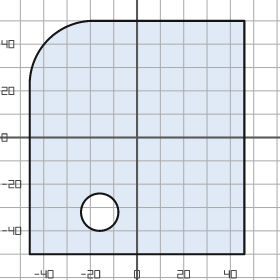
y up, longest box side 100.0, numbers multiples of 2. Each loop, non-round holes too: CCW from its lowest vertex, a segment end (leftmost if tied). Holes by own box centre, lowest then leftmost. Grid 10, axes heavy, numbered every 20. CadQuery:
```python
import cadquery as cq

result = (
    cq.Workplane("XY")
    .moveTo(-46.0, -50.0)
    .lineTo(46.0, -50.0)
    .lineTo(46.0, 50.0)
    .lineTo(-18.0, 50.0)
    .threePointArc((-38.0, 42.0), (-46.0, 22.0))
    .close()
    .moveTo(-16.0, -32.0)
    .circle(8.0)
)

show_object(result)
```